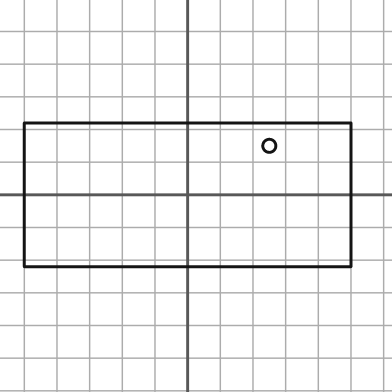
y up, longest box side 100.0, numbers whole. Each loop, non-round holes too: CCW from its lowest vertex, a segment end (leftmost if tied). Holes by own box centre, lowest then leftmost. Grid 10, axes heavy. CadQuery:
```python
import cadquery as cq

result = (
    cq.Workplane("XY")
    .moveTo(-50.0, -22.0)
    .lineTo(50.0, -22.0)
    .lineTo(50.0, 22.0)
    .lineTo(-50.0, 22.0)
    .close()
    .moveTo(25.0, 15.0)
    .circle(2.0)
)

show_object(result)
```